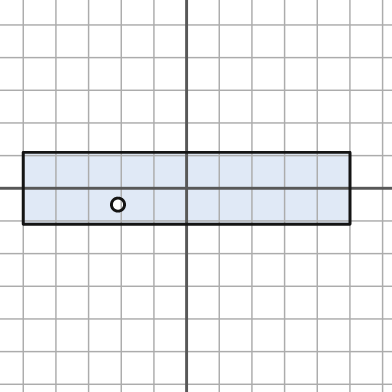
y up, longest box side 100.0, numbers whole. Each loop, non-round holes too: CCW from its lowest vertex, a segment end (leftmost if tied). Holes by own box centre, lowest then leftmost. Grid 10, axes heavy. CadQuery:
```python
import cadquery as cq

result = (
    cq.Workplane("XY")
    .moveTo(-50.0, -11.0)
    .lineTo(50.0, -11.0)
    .lineTo(50.0, 11.0)
    .lineTo(-50.0, 11.0)
    .close()
    .moveTo(-21.0, -5.0)
    .circle(2.0)
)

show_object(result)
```